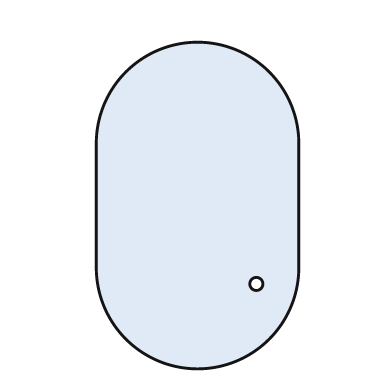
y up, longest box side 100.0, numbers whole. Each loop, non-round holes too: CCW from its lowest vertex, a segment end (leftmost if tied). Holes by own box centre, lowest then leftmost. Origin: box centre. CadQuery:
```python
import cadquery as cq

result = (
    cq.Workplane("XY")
    .moveTo(-31.0, -19.0)
    .threePointArc((0.0, -50.0), (31.0, -19.0))
    .lineTo(31.0, 19.0)
    .threePointArc((0.0, 50.0), (-31.0, 19.0))
    .close()
    .moveTo(18.0, -24.0)
    .circle(2.0)
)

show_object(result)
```